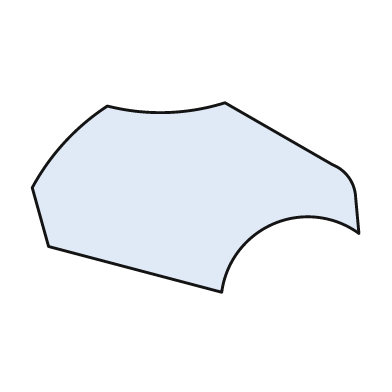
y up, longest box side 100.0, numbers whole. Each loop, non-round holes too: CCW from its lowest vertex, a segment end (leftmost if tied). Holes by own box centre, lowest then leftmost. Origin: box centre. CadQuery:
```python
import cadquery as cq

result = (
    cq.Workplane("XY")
    .moveTo(8.0, -29.0)
    .threePointArc((24.0, -8.0), (50.0, -11.0))
    .lineTo(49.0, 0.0)
    .threePointArc((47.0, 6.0), (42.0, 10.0))
    .lineTo(9.0, 29.0)
    .threePointArc((-9.0, 26.0), (-27.0, 28.0))
    .threePointArc((-40.0, 17.0), (-50.0, 3.0))
    .lineTo(-45.0, -15.0)
    .close()
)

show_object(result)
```